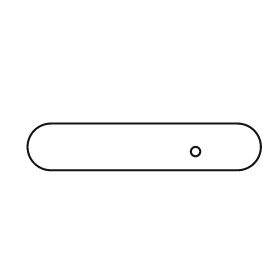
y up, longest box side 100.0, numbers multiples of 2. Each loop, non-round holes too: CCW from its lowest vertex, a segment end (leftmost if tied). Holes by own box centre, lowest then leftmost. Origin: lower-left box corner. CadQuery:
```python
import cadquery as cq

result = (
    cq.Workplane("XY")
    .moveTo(10.0, 0.0)
    .lineTo(90.0, 0.0)
    .threePointArc((100.0, 10.0), (90.0, 20.0))
    .lineTo(10.0, 20.0)
    .threePointArc((0.0, 10.0), (10.0, 0.0))
    .close()
    .moveTo(72.0, 8.0)
    .circle(2.0)
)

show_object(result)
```